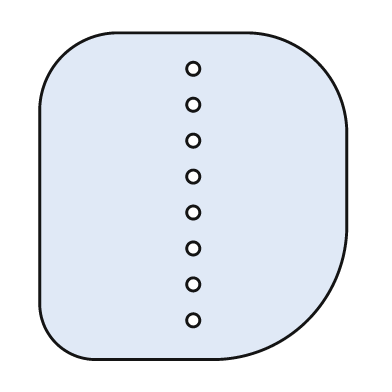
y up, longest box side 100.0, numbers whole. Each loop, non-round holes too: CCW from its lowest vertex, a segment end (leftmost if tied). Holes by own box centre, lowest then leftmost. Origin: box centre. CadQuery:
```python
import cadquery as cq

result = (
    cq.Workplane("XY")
    .moveTo(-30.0, -50.0)
    .lineTo(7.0, -50.0)
    .threePointArc((35.0, -38.0), (47.0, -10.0))
    .lineTo(47.0, 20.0)
    .threePointArc((38.0, 41.0), (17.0, 50.0))
    .lineTo(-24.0, 50.0)
    .threePointArc((-40.0, 43.0), (-47.0, 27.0))
    .lineTo(-47.0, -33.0)
    .threePointArc((-42.0, -45.0), (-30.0, -50.0))
    .close()
    .moveTo(0.0, -38.0)
    .circle(2.0)
    .moveTo(0.0, -27.0)
    .circle(2.0)
    .moveTo(0.0, -16.0)
    .circle(2.0)
    .moveTo(0.0, -5.0)
    .circle(2.0)
    .moveTo(0.0, 6.0)
    .circle(2.0)
    .moveTo(0.0, 17.0)
    .circle(2.0)
    .moveTo(0.0, 28.0)
    .circle(2.0)
    .moveTo(0.0, 39.0)
    .circle(2.0)
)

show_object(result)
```